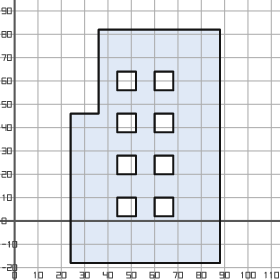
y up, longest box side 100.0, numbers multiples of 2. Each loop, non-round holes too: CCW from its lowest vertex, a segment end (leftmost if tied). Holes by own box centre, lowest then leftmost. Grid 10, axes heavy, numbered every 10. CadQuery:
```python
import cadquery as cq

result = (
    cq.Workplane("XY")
    .moveTo(24.0, -18.0)
    .lineTo(88.0, -18.0)
    .lineTo(88.0, 82.0)
    .lineTo(36.0, 82.0)
    .lineTo(36.0, 46.0)
    .lineTo(24.0, 46.0)
    .close()
    .moveTo(44.0, 2.0)
    .lineTo(52.0, 2.0)
    .lineTo(52.0, 10.0)
    .lineTo(44.0, 10.0)
    .close()
    .moveTo(60.0, 2.0)
    .lineTo(68.0, 2.0)
    .lineTo(68.0, 10.0)
    .lineTo(60.0, 10.0)
    .close()
    .moveTo(44.0, 20.0)
    .lineTo(52.0, 20.0)
    .lineTo(52.0, 28.0)
    .lineTo(44.0, 28.0)
    .close()
    .moveTo(60.0, 20.0)
    .lineTo(68.0, 20.0)
    .lineTo(68.0, 28.0)
    .lineTo(60.0, 28.0)
    .close()
    .moveTo(44.0, 38.0)
    .lineTo(52.0, 38.0)
    .lineTo(52.0, 46.0)
    .lineTo(44.0, 46.0)
    .close()
    .moveTo(60.0, 38.0)
    .lineTo(68.0, 38.0)
    .lineTo(68.0, 46.0)
    .lineTo(60.0, 46.0)
    .close()
    .moveTo(44.0, 56.0)
    .lineTo(52.0, 56.0)
    .lineTo(52.0, 64.0)
    .lineTo(44.0, 64.0)
    .close()
    .moveTo(60.0, 56.0)
    .lineTo(68.0, 56.0)
    .lineTo(68.0, 64.0)
    .lineTo(60.0, 64.0)
    .close()
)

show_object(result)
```